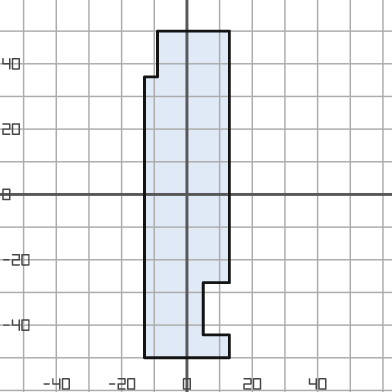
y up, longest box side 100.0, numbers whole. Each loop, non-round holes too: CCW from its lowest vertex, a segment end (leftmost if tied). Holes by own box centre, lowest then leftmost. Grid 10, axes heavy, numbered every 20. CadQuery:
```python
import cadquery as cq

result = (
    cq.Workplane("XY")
    .moveTo(-13.0, -50.0)
    .lineTo(13.0, -50.0)
    .lineTo(13.0, -43.0)
    .lineTo(5.0, -43.0)
    .lineTo(5.0, -27.0)
    .lineTo(13.0, -27.0)
    .lineTo(13.0, 50.0)
    .lineTo(-9.0, 50.0)
    .lineTo(-9.0, 36.0)
    .lineTo(-13.0, 36.0)
    .close()
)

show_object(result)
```